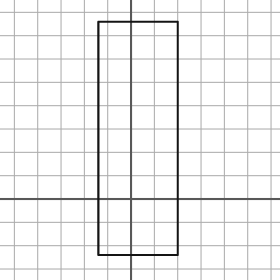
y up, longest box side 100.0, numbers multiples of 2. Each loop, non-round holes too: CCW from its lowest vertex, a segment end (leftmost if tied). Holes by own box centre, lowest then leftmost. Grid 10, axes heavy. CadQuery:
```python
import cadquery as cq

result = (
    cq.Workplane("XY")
    .moveTo(-14.0, -24.0)
    .lineTo(20.0, -24.0)
    .lineTo(20.0, 76.0)
    .lineTo(-14.0, 76.0)
    .close()
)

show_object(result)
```